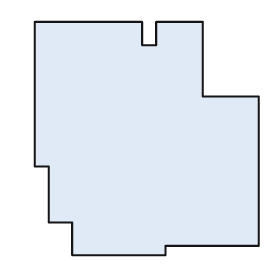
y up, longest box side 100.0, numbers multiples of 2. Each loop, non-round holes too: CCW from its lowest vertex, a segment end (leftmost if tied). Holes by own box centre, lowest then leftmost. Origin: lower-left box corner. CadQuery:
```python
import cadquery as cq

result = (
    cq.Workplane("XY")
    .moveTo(16.0, 0.0)
    .lineTo(56.0, 0.0)
    .lineTo(56.0, 4.0)
    .lineTo(96.0, 4.0)
    .lineTo(96.0, 68.0)
    .lineTo(72.0, 68.0)
    .lineTo(72.0, 100.0)
    .lineTo(52.0, 100.0)
    .lineTo(52.0, 90.0)
    .lineTo(46.0, 90.0)
    .lineTo(46.0, 100.0)
    .lineTo(0.0, 100.0)
    .lineTo(0.0, 38.0)
    .lineTo(6.0, 38.0)
    .lineTo(6.0, 14.0)
    .lineTo(16.0, 14.0)
    .close()
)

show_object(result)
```